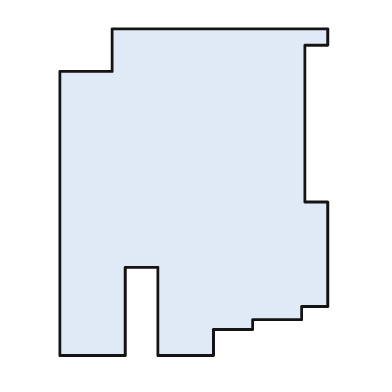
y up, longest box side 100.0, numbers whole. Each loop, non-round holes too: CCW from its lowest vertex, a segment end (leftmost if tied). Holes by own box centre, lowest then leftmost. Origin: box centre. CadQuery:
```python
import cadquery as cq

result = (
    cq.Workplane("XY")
    .moveTo(-41.0, -50.0)
    .lineTo(-21.0, -50.0)
    .lineTo(-21.0, -23.0)
    .lineTo(-11.0, -23.0)
    .lineTo(-11.0, -50.0)
    .lineTo(6.0, -50.0)
    .lineTo(6.0, -42.0)
    .lineTo(18.0, -42.0)
    .lineTo(18.0, -39.0)
    .lineTo(33.0, -39.0)
    .lineTo(33.0, -35.0)
    .lineTo(41.0, -35.0)
    .lineTo(41.0, -3.0)
    .lineTo(34.0, -3.0)
    .lineTo(34.0, 45.0)
    .lineTo(41.0, 45.0)
    .lineTo(41.0, 50.0)
    .lineTo(-25.0, 50.0)
    .lineTo(-25.0, 37.0)
    .lineTo(-41.0, 37.0)
    .close()
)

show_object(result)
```